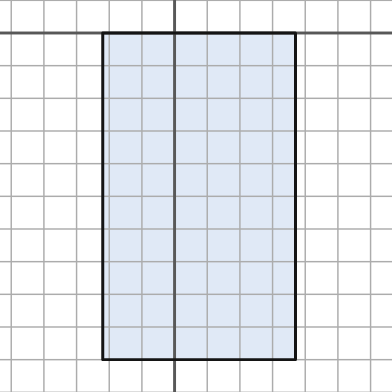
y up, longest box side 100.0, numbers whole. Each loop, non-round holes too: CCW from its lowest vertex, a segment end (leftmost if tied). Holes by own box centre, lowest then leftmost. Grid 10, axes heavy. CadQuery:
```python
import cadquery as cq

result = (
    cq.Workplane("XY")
    .moveTo(-22.0, -100.0)
    .lineTo(37.0, -100.0)
    .lineTo(37.0, 0.0)
    .lineTo(-22.0, 0.0)
    .close()
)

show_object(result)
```